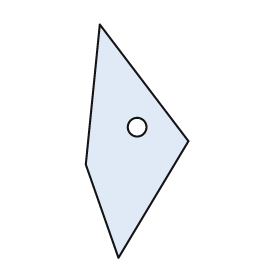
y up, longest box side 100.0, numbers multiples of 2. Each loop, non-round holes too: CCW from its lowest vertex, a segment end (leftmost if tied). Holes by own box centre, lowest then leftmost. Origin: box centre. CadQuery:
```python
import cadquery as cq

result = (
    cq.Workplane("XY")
    .moveTo(-8.0, -50.0)
    .lineTo(22.0, 0.0)
    .lineTo(-16.0, 50.0)
    .lineTo(-22.0, -10.0)
    .close()
    .moveTo(0.0, 6.0)
    .circle(4.0)
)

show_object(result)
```